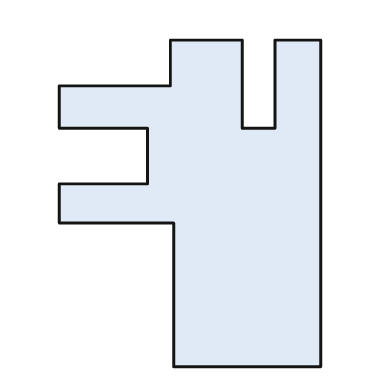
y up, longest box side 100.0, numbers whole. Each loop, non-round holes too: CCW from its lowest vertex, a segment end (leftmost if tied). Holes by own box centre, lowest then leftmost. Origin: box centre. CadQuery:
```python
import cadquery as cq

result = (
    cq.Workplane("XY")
    .moveTo(-5.0, -50.0)
    .lineTo(40.0, -50.0)
    .lineTo(40.0, 50.0)
    .lineTo(26.0, 50.0)
    .lineTo(26.0, 23.0)
    .lineTo(16.0, 23.0)
    .lineTo(16.0, 50.0)
    .lineTo(-6.0, 50.0)
    .lineTo(-6.0, 36.0)
    .lineTo(-40.0, 36.0)
    .lineTo(-40.0, 23.0)
    .lineTo(-13.0, 23.0)
    .lineTo(-13.0, 6.0)
    .lineTo(-40.0, 6.0)
    .lineTo(-40.0, -6.0)
    .lineTo(-5.0, -6.0)
    .close()
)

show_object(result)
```